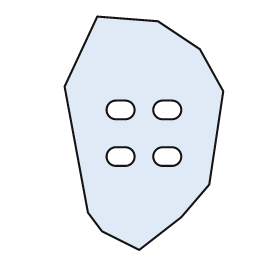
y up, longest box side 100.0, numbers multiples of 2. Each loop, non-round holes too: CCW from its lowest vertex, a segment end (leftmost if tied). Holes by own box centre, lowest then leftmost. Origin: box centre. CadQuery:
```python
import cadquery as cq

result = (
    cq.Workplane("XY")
    .moveTo(-2.0, -50.0)
    .lineTo(16.0, -36.0)
    .lineTo(28.0, -22.0)
    .lineTo(34.0, 18.0)
    .lineTo(24.0, 36.0)
    .lineTo(6.0, 48.0)
    .lineTo(-20.0, 50.0)
    .lineTo(-34.0, 20.0)
    .lineTo(-24.0, -34.0)
    .lineTo(-18.0, -42.0)
    .close()
    .moveTo(-12.0, -14.0)
    .lineTo(-8.0, -14.0)
    .threePointArc((-4.0, -10.0), (-8.0, -6.0))
    .lineTo(-12.0, -6.0)
    .threePointArc((-16.0, -10.0), (-12.0, -14.0))
    .close()
    .moveTo(8.0, -14.0)
    .lineTo(12.0, -14.0)
    .threePointArc((16.0, -10.0), (12.0, -6.0))
    .lineTo(8.0, -6.0)
    .threePointArc((4.0, -10.0), (8.0, -14.0))
    .close()
    .moveTo(-12.0, 6.0)
    .lineTo(-8.0, 6.0)
    .threePointArc((-4.0, 10.0), (-8.0, 14.0))
    .lineTo(-12.0, 14.0)
    .threePointArc((-16.0, 10.0), (-12.0, 6.0))
    .close()
    .moveTo(8.0, 6.0)
    .lineTo(12.0, 6.0)
    .threePointArc((16.0, 10.0), (12.0, 14.0))
    .lineTo(8.0, 14.0)
    .threePointArc((4.0, 10.0), (8.0, 6.0))
    .close()
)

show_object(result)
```